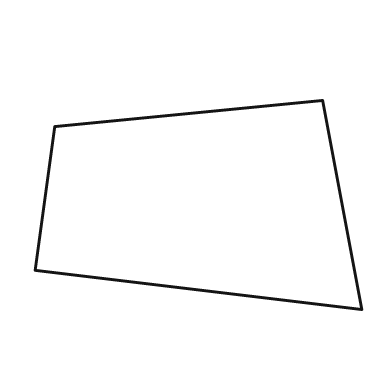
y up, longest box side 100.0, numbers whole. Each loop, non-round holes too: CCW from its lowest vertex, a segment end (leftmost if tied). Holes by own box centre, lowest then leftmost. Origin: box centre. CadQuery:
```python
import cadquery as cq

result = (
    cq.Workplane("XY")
    .moveTo(50.0, -32.0)
    .lineTo(38.0, 32.0)
    .lineTo(-44.0, 24.0)
    .lineTo(-50.0, -20.0)
    .close()
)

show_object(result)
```